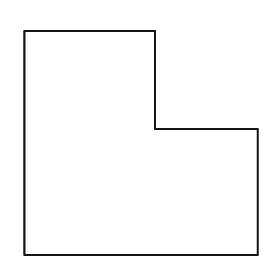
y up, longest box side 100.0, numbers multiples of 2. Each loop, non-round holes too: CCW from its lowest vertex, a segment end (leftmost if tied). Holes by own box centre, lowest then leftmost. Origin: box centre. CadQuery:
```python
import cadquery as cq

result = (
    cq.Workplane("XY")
    .moveTo(-50.0, -48.0)
    .lineTo(50.0, -48.0)
    .lineTo(50.0, 6.0)
    .lineTo(6.0, 6.0)
    .lineTo(6.0, 48.0)
    .lineTo(-50.0, 48.0)
    .close()
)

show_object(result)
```